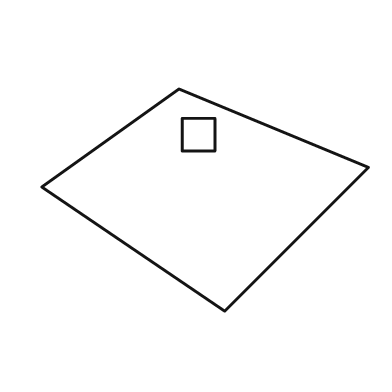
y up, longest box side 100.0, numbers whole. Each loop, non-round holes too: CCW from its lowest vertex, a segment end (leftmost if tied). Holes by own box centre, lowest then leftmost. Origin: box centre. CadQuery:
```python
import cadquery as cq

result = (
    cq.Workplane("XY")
    .moveTo(6.0, -34.0)
    .lineTo(50.0, 10.0)
    .lineTo(-8.0, 34.0)
    .lineTo(-50.0, 4.0)
    .close()
    .moveTo(-7.0, 15.0)
    .lineTo(3.0, 15.0)
    .lineTo(3.0, 25.0)
    .lineTo(-7.0, 25.0)
    .close()
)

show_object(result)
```